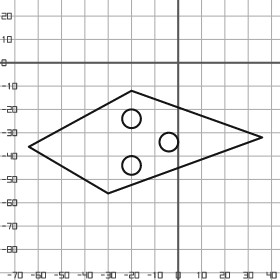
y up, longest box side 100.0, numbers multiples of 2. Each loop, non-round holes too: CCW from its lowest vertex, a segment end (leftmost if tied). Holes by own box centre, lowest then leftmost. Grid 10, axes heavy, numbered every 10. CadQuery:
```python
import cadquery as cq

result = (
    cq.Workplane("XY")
    .moveTo(-30.0, -56.0)
    .lineTo(36.0, -32.0)
    .lineTo(-20.0, -12.0)
    .lineTo(-64.0, -36.0)
    .close()
    .moveTo(-20.0, -44.0)
    .circle(4.0)
    .moveTo(-4.0, -34.0)
    .circle(4.0)
    .moveTo(-20.0, -24.0)
    .circle(4.0)
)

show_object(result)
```